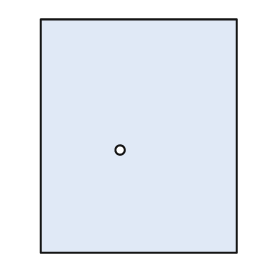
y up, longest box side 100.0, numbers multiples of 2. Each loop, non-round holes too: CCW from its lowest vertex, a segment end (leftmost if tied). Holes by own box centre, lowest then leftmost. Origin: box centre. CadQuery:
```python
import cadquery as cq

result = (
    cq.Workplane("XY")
    .moveTo(-42.0, -50.0)
    .lineTo(42.0, -50.0)
    .lineTo(42.0, 50.0)
    .lineTo(-42.0, 50.0)
    .close()
    .moveTo(-8.0, -6.0)
    .circle(2.0)
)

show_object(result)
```